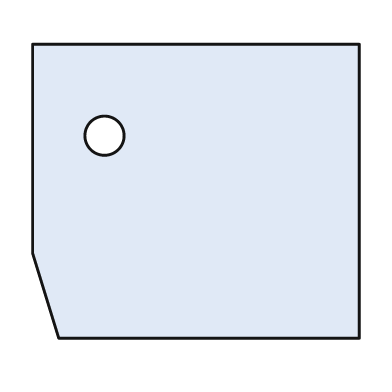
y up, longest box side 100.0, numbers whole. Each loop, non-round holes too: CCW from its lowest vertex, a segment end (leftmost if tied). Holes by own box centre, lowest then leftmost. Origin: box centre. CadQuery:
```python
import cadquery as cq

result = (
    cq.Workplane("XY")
    .moveTo(-42.0, -45.0)
    .lineTo(50.0, -45.0)
    .lineTo(50.0, 45.0)
    .lineTo(-50.0, 45.0)
    .lineTo(-50.0, -19.0)
    .close()
    .moveTo(-28.0, 17.0)
    .circle(6.0)
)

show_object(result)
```